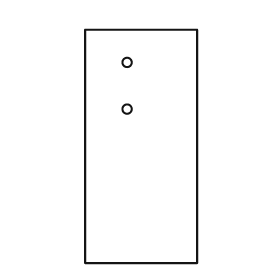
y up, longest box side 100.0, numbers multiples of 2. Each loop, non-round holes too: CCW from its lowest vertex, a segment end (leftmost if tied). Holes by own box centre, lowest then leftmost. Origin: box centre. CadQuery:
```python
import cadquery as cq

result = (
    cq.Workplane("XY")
    .moveTo(-24.0, -50.0)
    .lineTo(24.0, -50.0)
    .lineTo(24.0, 50.0)
    .lineTo(-24.0, 50.0)
    .close()
    .moveTo(-6.0, 16.0)
    .circle(2.0)
    .moveTo(-6.0, 36.0)
    .circle(2.0)
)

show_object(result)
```